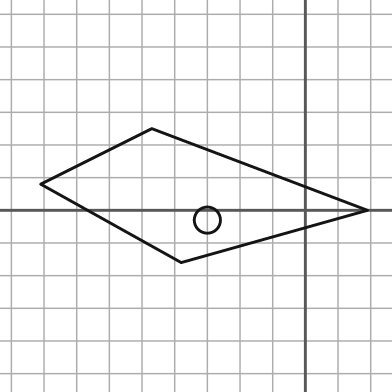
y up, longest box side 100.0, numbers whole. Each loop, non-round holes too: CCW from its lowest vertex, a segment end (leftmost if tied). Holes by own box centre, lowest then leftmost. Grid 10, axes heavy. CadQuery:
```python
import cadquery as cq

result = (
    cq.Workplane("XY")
    .moveTo(-38.0, -16.0)
    .lineTo(19.0, 0.0)
    .lineTo(-47.0, 25.0)
    .lineTo(-81.0, 8.0)
    .close()
    .moveTo(-30.0, -3.0)
    .circle(4.0)
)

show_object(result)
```